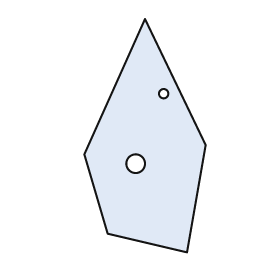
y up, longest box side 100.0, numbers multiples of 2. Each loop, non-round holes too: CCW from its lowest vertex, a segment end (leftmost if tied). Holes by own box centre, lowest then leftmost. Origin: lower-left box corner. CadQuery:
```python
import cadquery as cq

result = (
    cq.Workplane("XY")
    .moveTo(44.0, 0.0)
    .lineTo(52.0, 46.0)
    .lineTo(26.0, 100.0)
    .lineTo(0.0, 42.0)
    .lineTo(10.0, 8.0)
    .close()
    .moveTo(22.0, 38.0)
    .circle(4.0)
    .moveTo(34.0, 68.0)
    .circle(2.0)
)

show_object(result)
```